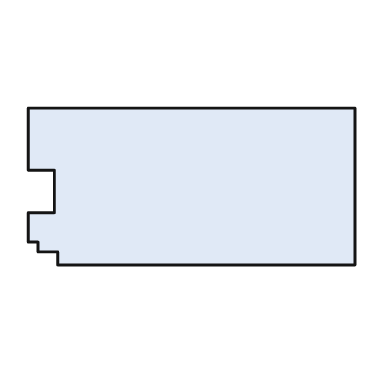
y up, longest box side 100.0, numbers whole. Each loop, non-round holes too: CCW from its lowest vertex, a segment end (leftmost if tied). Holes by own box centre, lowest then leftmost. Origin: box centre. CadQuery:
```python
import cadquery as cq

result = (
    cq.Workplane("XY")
    .moveTo(-41.0, -24.0)
    .lineTo(50.0, -24.0)
    .lineTo(50.0, 24.0)
    .lineTo(-50.0, 24.0)
    .lineTo(-50.0, 5.0)
    .lineTo(-42.0, 5.0)
    .lineTo(-42.0, -8.0)
    .lineTo(-50.0, -8.0)
    .lineTo(-50.0, -17.0)
    .lineTo(-47.0, -17.0)
    .lineTo(-47.0, -20.0)
    .lineTo(-41.0, -20.0)
    .close()
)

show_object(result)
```